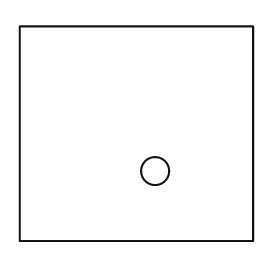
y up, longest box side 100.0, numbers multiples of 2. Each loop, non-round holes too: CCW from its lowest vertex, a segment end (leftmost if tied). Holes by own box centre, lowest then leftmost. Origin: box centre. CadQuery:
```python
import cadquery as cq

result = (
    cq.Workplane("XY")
    .moveTo(-50.0, -46.0)
    .lineTo(50.0, -46.0)
    .lineTo(50.0, 46.0)
    .lineTo(-50.0, 46.0)
    .close()
    .moveTo(8.0, -16.0)
    .circle(6.0)
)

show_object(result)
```